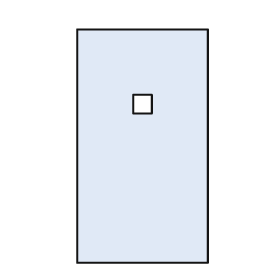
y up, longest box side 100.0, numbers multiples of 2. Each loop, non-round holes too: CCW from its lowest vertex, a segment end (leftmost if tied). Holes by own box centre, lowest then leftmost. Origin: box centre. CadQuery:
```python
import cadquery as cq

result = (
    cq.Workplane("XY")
    .moveTo(-28.0, -50.0)
    .lineTo(28.0, -50.0)
    .lineTo(28.0, 50.0)
    .lineTo(-28.0, 50.0)
    .close()
    .moveTo(-4.0, 14.0)
    .lineTo(4.0, 14.0)
    .lineTo(4.0, 22.0)
    .lineTo(-4.0, 22.0)
    .close()
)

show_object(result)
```